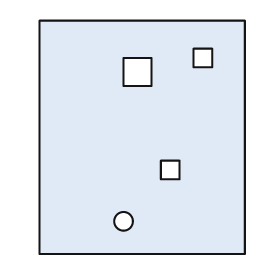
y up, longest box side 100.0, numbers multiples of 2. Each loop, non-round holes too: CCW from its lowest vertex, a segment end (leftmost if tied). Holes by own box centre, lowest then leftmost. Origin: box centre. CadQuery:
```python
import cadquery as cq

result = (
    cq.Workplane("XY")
    .moveTo(-44.0, -50.0)
    .lineTo(44.0, -50.0)
    .lineTo(44.0, 50.0)
    .lineTo(-44.0, 50.0)
    .close()
    .moveTo(-8.0, -36.0)
    .circle(4.0)
    .moveTo(8.0, -18.0)
    .lineTo(16.0, -18.0)
    .lineTo(16.0, -10.0)
    .lineTo(8.0, -10.0)
    .close()
    .moveTo(-8.0, 22.0)
    .lineTo(4.0, 22.0)
    .lineTo(4.0, 34.0)
    .lineTo(-8.0, 34.0)
    .close()
    .moveTo(22.0, 30.0)
    .lineTo(30.0, 30.0)
    .lineTo(30.0, 38.0)
    .lineTo(22.0, 38.0)
    .close()
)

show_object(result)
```